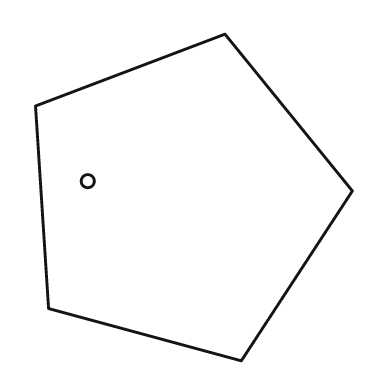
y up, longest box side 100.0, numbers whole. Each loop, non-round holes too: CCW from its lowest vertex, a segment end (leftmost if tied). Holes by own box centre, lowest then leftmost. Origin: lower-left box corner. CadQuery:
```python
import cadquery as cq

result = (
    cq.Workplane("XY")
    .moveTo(63.0, 0.0)
    .lineTo(97.0, 52.0)
    .lineTo(58.0, 100.0)
    .lineTo(0.0, 78.0)
    .lineTo(4.0, 16.0)
    .close()
    .moveTo(16.0, 55.0)
    .circle(2.0)
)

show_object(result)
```